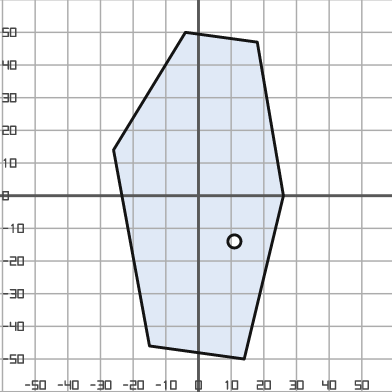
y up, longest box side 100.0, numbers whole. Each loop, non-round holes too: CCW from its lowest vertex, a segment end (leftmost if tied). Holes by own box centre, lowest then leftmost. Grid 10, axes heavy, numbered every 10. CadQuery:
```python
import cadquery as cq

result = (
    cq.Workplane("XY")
    .moveTo(14.0, -50.0)
    .lineTo(26.0, 0.0)
    .lineTo(18.0, 47.0)
    .lineTo(-4.0, 50.0)
    .lineTo(-26.0, 14.0)
    .lineTo(-15.0, -46.0)
    .close()
    .moveTo(11.0, -14.0)
    .circle(2.0)
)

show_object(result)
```